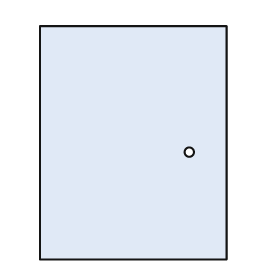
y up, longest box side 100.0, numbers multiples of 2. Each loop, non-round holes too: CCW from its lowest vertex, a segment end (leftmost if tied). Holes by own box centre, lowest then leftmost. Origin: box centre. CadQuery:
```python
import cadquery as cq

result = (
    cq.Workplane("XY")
    .moveTo(-40.0, -50.0)
    .lineTo(40.0, -50.0)
    .lineTo(40.0, 50.0)
    .lineTo(-40.0, 50.0)
    .close()
    .moveTo(24.0, -4.0)
    .circle(2.0)
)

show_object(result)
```